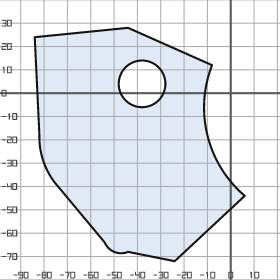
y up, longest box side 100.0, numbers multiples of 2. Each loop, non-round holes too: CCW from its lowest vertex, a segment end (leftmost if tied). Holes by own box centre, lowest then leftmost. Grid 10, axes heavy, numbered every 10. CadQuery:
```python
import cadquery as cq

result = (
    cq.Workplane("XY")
    .moveTo(-24.0, -72.0)
    .lineTo(6.0, -44.0)
    .threePointArc((-10.0, -18.0), (-8.0, 12.0))
    .lineTo(-44.0, 28.0)
    .lineTo(-84.0, 24.0)
    .lineTo(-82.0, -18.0)
    .threePointArc((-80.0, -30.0), (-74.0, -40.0))
    .lineTo(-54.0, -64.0)
    .threePointArc((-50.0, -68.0), (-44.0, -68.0))
    .close()
    .moveTo(-38.0, 4.0)
    .circle(10.0)
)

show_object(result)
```